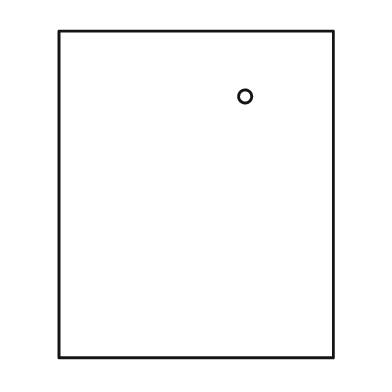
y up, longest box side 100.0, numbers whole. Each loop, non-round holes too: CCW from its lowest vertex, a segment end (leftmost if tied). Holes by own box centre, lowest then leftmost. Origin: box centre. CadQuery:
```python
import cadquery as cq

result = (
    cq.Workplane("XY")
    .moveTo(-42.0, -50.0)
    .lineTo(42.0, -50.0)
    .lineTo(42.0, 50.0)
    .lineTo(-42.0, 50.0)
    .close()
    .moveTo(15.0, 30.0)
    .circle(2.0)
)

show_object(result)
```